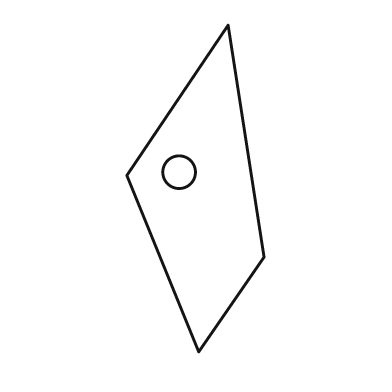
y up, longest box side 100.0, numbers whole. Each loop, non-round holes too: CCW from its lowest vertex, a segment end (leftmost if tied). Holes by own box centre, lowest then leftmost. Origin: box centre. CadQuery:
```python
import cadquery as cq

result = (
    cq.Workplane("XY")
    .moveTo(1.0, -50.0)
    .lineTo(21.0, -21.0)
    .lineTo(10.0, 50.0)
    .lineTo(-21.0, 4.0)
    .close()
    .moveTo(-5.0, 5.0)
    .circle(5.0)
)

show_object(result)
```